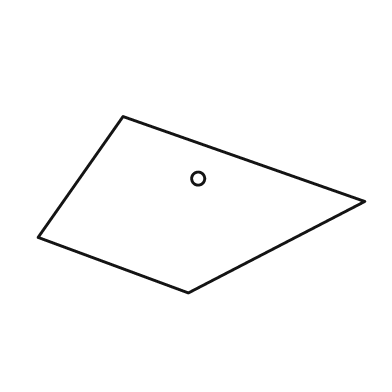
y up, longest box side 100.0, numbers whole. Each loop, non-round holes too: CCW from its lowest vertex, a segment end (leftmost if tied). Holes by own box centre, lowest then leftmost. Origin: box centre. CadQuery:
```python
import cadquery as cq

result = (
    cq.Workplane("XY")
    .moveTo(-4.0, -27.0)
    .lineTo(50.0, 1.0)
    .lineTo(-24.0, 27.0)
    .lineTo(-50.0, -10.0)
    .close()
    .moveTo(-1.0, 8.0)
    .circle(2.0)
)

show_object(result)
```